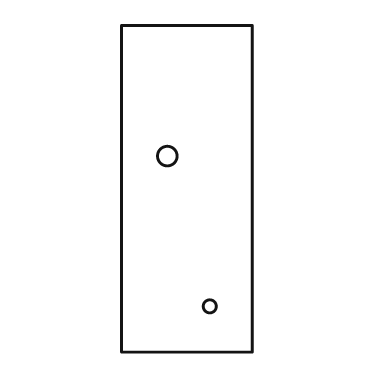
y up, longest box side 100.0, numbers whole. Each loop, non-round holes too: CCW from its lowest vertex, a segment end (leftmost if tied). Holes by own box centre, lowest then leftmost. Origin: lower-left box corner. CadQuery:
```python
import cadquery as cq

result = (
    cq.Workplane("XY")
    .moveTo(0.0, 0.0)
    .lineTo(40.0, 0.0)
    .lineTo(40.0, 100.0)
    .lineTo(0.0, 100.0)
    .close()
    .moveTo(27.0, 14.0)
    .circle(2.0)
    .moveTo(14.0, 60.0)
    .circle(3.0)
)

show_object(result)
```